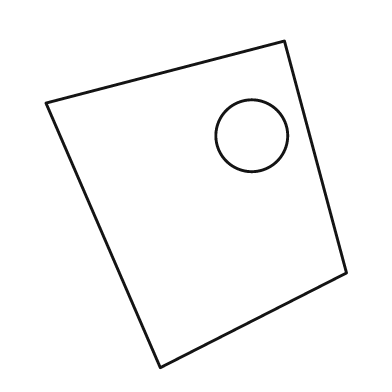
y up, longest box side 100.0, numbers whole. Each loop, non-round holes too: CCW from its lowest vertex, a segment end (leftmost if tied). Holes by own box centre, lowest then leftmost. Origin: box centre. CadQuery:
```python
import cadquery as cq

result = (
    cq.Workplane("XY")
    .moveTo(-11.0, -50.0)
    .lineTo(46.0, -21.0)
    .lineTo(27.0, 50.0)
    .lineTo(-46.0, 31.0)
    .close()
    .moveTo(17.0, 21.0)
    .circle(11.0)
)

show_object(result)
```